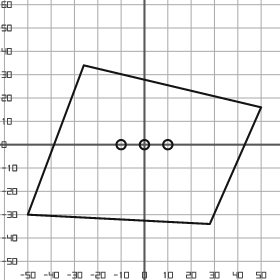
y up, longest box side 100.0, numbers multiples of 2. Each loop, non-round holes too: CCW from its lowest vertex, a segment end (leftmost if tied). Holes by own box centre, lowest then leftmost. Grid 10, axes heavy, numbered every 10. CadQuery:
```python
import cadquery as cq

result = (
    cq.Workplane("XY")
    .moveTo(28.0, -34.0)
    .lineTo(50.0, 16.0)
    .lineTo(-26.0, 34.0)
    .lineTo(-50.0, -30.0)
    .close()
    .moveTo(-10.0, 0.0)
    .circle(2.0)
    .moveTo(0.0, 0.0)
    .circle(2.0)
    .moveTo(10.0, 0.0)
    .circle(2.0)
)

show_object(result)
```